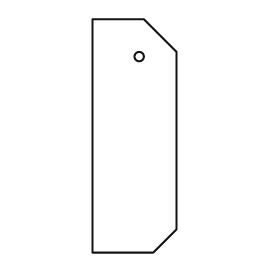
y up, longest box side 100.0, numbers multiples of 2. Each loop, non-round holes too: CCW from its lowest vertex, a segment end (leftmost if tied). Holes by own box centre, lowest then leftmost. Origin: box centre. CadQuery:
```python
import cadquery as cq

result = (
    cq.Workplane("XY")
    .moveTo(-18.0, -50.0)
    .lineTo(8.0, -50.0)
    .lineTo(18.0, -40.0)
    .lineTo(18.0, 36.0)
    .lineTo(4.0, 50.0)
    .lineTo(-18.0, 50.0)
    .close()
    .moveTo(2.0, 34.0)
    .circle(2.0)
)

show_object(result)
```